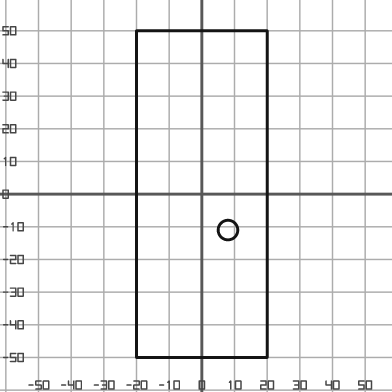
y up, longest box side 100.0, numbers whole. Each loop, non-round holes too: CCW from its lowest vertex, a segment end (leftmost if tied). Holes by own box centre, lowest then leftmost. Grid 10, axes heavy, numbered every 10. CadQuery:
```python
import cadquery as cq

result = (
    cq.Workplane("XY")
    .moveTo(-20.0, -50.0)
    .lineTo(20.0, -50.0)
    .lineTo(20.0, 50.0)
    .lineTo(-20.0, 50.0)
    .close()
    .moveTo(8.0, -11.0)
    .circle(3.0)
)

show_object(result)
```